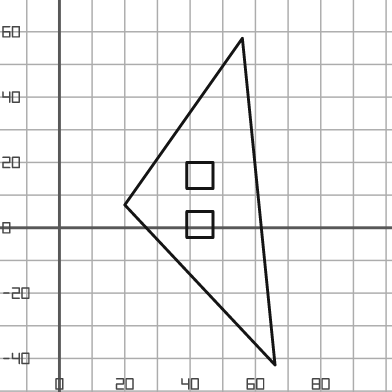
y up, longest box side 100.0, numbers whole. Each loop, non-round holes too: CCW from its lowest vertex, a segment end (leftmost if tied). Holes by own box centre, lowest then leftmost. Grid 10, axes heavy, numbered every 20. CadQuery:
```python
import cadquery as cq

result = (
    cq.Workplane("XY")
    .moveTo(66.0, -42.0)
    .lineTo(56.0, 58.0)
    .lineTo(20.0, 7.0)
    .close()
    .moveTo(39.0, -3.0)
    .lineTo(47.0, -3.0)
    .lineTo(47.0, 5.0)
    .lineTo(39.0, 5.0)
    .close()
    .moveTo(39.0, 12.0)
    .lineTo(47.0, 12.0)
    .lineTo(47.0, 20.0)
    .lineTo(39.0, 20.0)
    .close()
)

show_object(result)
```